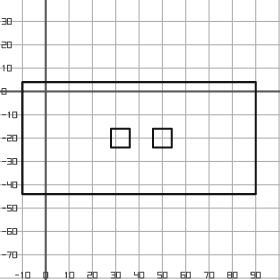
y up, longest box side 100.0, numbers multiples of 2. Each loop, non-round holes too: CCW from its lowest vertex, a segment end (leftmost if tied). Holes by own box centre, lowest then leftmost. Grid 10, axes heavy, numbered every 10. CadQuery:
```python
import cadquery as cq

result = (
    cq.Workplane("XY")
    .moveTo(-10.0, -44.0)
    .lineTo(90.0, -44.0)
    .lineTo(90.0, 4.0)
    .lineTo(-10.0, 4.0)
    .close()
    .moveTo(28.0, -24.0)
    .lineTo(36.0, -24.0)
    .lineTo(36.0, -16.0)
    .lineTo(28.0, -16.0)
    .close()
    .moveTo(46.0, -24.0)
    .lineTo(54.0, -24.0)
    .lineTo(54.0, -16.0)
    .lineTo(46.0, -16.0)
    .close()
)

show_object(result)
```